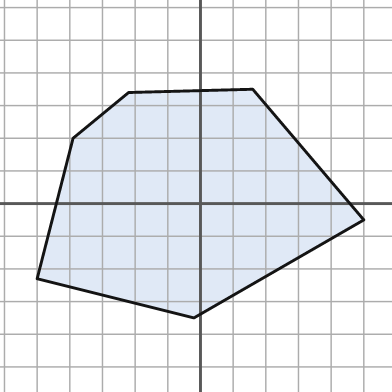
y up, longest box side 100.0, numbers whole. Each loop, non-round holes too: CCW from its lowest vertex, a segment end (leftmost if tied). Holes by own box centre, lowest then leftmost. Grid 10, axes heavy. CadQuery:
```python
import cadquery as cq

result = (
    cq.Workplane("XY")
    .moveTo(-2.0, -35.0)
    .lineTo(50.0, -5.0)
    .lineTo(16.0, 35.0)
    .lineTo(-22.0, 34.0)
    .lineTo(-39.0, 20.0)
    .lineTo(-50.0, -23.0)
    .close()
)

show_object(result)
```